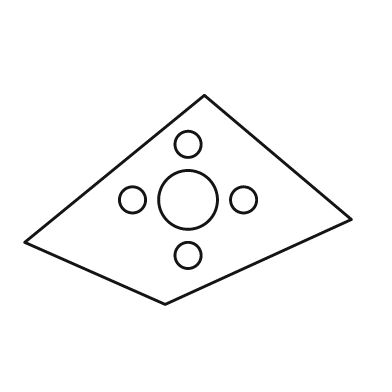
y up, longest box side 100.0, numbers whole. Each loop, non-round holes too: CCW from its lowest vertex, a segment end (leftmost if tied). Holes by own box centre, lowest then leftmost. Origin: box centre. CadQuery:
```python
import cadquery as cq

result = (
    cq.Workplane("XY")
    .moveTo(-7.0, -32.0)
    .lineTo(50.0, -6.0)
    .lineTo(5.0, 32.0)
    .lineTo(-50.0, -13.0)
    .close()
    .moveTo(0.0, -17.0)
    .circle(4.0)
    .moveTo(-17.0, 0.0)
    .circle(4.0)
    .moveTo(0.0, 0.0)
    .circle(9.0)
    .moveTo(17.0, 0.0)
    .circle(4.0)
    .moveTo(0.0, 17.0)
    .circle(4.0)
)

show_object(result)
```